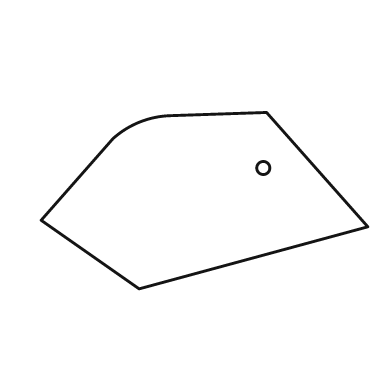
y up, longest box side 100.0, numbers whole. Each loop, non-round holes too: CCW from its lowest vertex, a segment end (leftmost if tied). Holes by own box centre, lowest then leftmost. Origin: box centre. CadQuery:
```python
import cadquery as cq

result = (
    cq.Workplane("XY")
    .moveTo(-20.0, -27.0)
    .lineTo(50.0, -8.0)
    .lineTo(19.0, 27.0)
    .lineTo(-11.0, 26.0)
    .threePointArc((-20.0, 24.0), (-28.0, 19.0))
    .lineTo(-50.0, -6.0)
    .close()
    .moveTo(18.0, 10.0)
    .circle(2.0)
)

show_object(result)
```